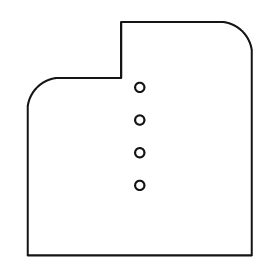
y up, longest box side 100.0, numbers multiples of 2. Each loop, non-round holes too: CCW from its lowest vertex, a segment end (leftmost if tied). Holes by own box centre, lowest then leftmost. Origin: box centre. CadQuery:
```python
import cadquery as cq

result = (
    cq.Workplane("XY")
    .moveTo(-48.0, -50.0)
    .lineTo(48.0, -50.0)
    .lineTo(48.0, 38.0)
    .threePointArc((44.0, 46.0), (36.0, 50.0))
    .lineTo(-8.0, 50.0)
    .lineTo(-8.0, 26.0)
    .lineTo(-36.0, 26.0)
    .threePointArc((-44.0, 22.0), (-48.0, 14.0))
    .close()
    .moveTo(0.0, -20.0)
    .circle(2.0)
    .moveTo(0.0, -6.0)
    .circle(2.0)
    .moveTo(0.0, 8.0)
    .circle(2.0)
    .moveTo(0.0, 22.0)
    .circle(2.0)
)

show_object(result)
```